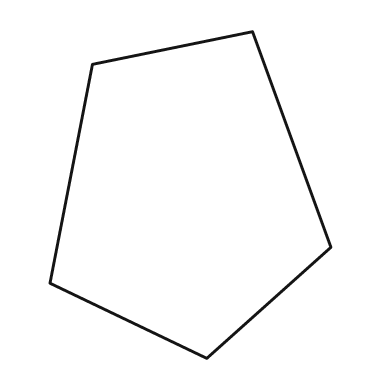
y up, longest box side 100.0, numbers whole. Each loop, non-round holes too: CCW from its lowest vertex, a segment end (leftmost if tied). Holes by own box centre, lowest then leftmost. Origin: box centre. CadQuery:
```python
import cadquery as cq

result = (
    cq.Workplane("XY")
    .moveTo(5.0, -50.0)
    .lineTo(43.0, -16.0)
    .lineTo(19.0, 50.0)
    .lineTo(-30.0, 40.0)
    .lineTo(-43.0, -27.0)
    .close()
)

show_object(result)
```